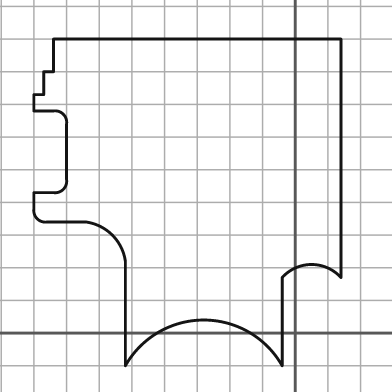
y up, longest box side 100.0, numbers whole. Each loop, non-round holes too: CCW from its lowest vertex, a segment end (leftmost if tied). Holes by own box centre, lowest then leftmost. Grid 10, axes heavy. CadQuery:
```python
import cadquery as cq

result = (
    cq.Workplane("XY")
    .moveTo(-52.0, -10.0)
    .threePointArc((-28.0, 4.0), (-4.0, -10.0))
    .lineTo(-4.0, 17.0)
    .threePointArc((5.0, 21.0), (14.0, 17.0))
    .lineTo(14.0, 90.0)
    .lineTo(-74.0, 90.0)
    .lineTo(-74.0, 80.0)
    .lineTo(-77.0, 80.0)
    .lineTo(-77.0, 73.0)
    .lineTo(-80.0, 73.0)
    .lineTo(-80.0, 68.0)
    .lineTo(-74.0, 68.0)
    .threePointArc((-71.0, 67.0), (-70.0, 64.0))
    .lineTo(-70.0, 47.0)
    .threePointArc((-71.0, 44.0), (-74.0, 43.0))
    .lineTo(-80.0, 43.0)
    .lineTo(-80.0, 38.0)
    .threePointArc((-79.0, 35.0), (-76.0, 34.0))
    .lineTo(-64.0, 34.0)
    .threePointArc((-56.0, 30.0), (-52.0, 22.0))
    .close()
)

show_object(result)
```